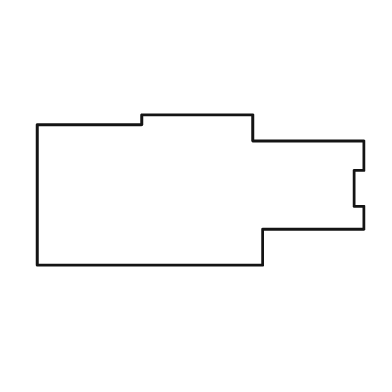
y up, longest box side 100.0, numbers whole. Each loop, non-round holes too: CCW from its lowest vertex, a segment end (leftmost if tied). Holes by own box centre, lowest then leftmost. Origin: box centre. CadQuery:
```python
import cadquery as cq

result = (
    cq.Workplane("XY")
    .moveTo(-50.0, -23.0)
    .lineTo(19.0, -23.0)
    .lineTo(19.0, -12.0)
    .lineTo(50.0, -12.0)
    .lineTo(50.0, -5.0)
    .lineTo(47.0, -5.0)
    .lineTo(47.0, 6.0)
    .lineTo(50.0, 6.0)
    .lineTo(50.0, 15.0)
    .lineTo(16.0, 15.0)
    .lineTo(16.0, 23.0)
    .lineTo(-18.0, 23.0)
    .lineTo(-18.0, 20.0)
    .lineTo(-50.0, 20.0)
    .close()
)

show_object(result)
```